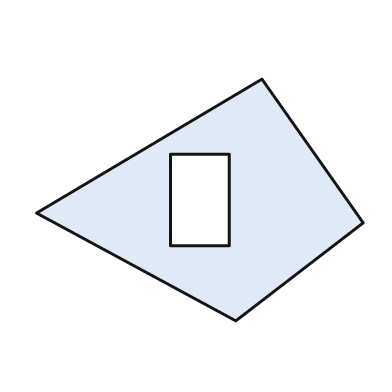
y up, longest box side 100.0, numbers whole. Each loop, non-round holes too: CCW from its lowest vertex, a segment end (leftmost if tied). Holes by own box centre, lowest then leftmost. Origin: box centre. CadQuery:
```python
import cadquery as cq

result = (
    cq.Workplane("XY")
    .moveTo(11.0, -37.0)
    .lineTo(50.0, -7.0)
    .lineTo(19.0, 37.0)
    .lineTo(-50.0, -4.0)
    .close()
    .moveTo(-9.0, -14.0)
    .lineTo(9.0, -14.0)
    .lineTo(9.0, 14.0)
    .lineTo(-9.0, 14.0)
    .close()
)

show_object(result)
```